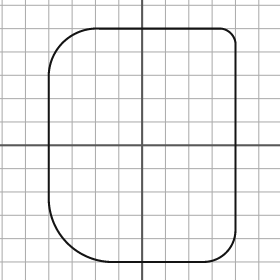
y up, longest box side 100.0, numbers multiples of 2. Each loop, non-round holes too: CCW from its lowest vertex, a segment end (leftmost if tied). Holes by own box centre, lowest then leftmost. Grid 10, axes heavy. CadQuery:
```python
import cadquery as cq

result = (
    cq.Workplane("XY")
    .moveTo(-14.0, -50.0)
    .lineTo(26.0, -50.0)
    .threePointArc((36.0, -46.0), (40.0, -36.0))
    .lineTo(40.0, 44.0)
    .threePointArc((38.0, 48.0), (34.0, 50.0))
    .lineTo(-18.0, 50.0)
    .threePointArc((-34.0, 44.0), (-40.0, 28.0))
    .lineTo(-40.0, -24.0)
    .threePointArc((-32.0, -42.0), (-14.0, -50.0))
    .close()
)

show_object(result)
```